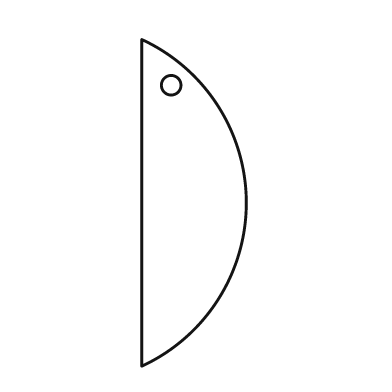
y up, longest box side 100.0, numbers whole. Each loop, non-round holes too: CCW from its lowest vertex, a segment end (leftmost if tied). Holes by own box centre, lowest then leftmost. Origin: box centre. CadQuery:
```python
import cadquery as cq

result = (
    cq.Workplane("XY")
    .moveTo(-16.0, -50.0)
    .threePointArc((16.0, 0.0), (-16.0, 50.0))
    .close()
    .moveTo(-7.0, 36.0)
    .circle(3.0)
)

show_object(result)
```